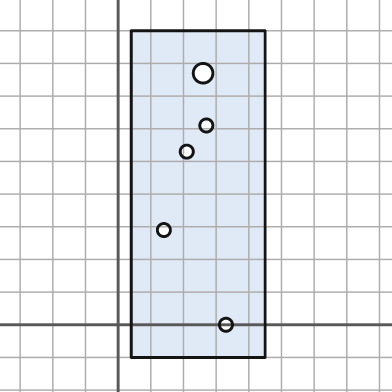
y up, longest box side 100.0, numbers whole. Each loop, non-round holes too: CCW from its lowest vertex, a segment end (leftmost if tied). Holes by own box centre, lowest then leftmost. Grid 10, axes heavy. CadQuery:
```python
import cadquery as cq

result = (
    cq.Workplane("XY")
    .moveTo(4.0, -10.0)
    .lineTo(45.0, -10.0)
    .lineTo(45.0, 90.0)
    .lineTo(4.0, 90.0)
    .close()
    .moveTo(33.0, 0.0)
    .circle(2.0)
    .moveTo(14.0, 29.0)
    .circle(2.0)
    .moveTo(21.0, 53.0)
    .circle(2.0)
    .moveTo(27.0, 61.0)
    .circle(2.0)
    .moveTo(26.0, 77.0)
    .circle(3.0)
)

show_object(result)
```